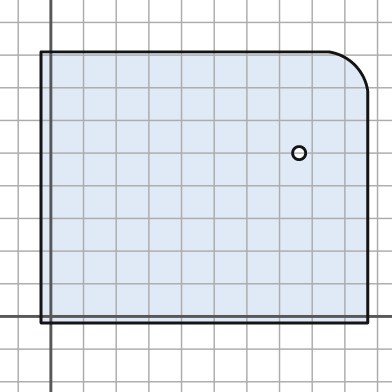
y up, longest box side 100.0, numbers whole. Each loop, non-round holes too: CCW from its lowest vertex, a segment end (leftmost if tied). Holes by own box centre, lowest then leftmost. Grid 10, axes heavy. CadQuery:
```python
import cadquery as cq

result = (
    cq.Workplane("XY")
    .moveTo(-3.0, -2.0)
    .lineTo(97.0, -2.0)
    .lineTo(97.0, 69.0)
    .threePointArc((93.0, 77.0), (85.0, 81.0))
    .lineTo(-3.0, 81.0)
    .close()
    .moveTo(76.0, 50.0)
    .circle(2.0)
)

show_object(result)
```